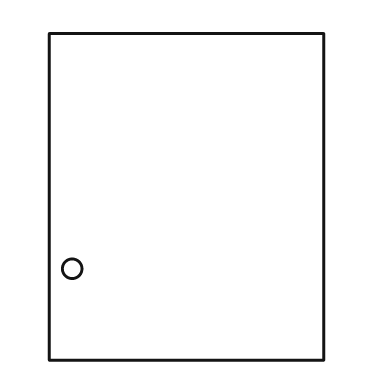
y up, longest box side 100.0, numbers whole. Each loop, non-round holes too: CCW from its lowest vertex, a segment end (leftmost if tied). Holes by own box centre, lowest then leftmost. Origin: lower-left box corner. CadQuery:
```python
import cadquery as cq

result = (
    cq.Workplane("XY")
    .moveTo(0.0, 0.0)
    .lineTo(84.0, 0.0)
    .lineTo(84.0, 100.0)
    .lineTo(0.0, 100.0)
    .close()
    .moveTo(7.0, 28.0)
    .circle(3.0)
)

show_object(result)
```